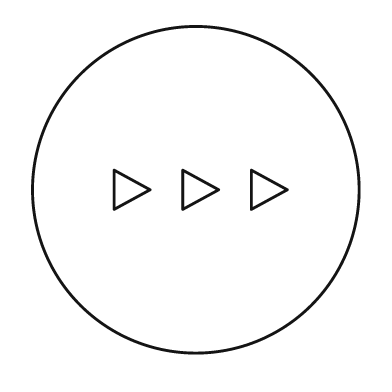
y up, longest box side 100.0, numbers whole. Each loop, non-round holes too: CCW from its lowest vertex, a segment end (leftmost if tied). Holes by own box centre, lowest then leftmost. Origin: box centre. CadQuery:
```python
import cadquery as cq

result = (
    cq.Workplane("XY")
    .moveTo(0.0, 0.0)
    .circle(50.0)
    .moveTo(-25.0, -6.0)
    .lineTo(-14.0, 0.0)
    .lineTo(-25.0, 6.0)
    .close()
    .moveTo(-4.0, -6.0)
    .lineTo(7.0, 0.0)
    .lineTo(-4.0, 6.0)
    .close()
    .moveTo(17.0, -6.0)
    .lineTo(28.0, 0.0)
    .lineTo(17.0, 6.0)
    .close()
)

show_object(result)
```